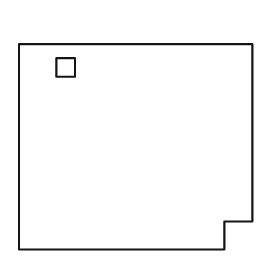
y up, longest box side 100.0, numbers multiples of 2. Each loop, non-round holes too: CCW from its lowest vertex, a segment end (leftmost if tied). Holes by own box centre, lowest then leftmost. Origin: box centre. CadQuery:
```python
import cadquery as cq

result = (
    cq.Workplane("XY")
    .moveTo(-50.0, -44.0)
    .lineTo(38.0, -44.0)
    .lineTo(38.0, -32.0)
    .lineTo(50.0, -32.0)
    .lineTo(50.0, 44.0)
    .lineTo(-50.0, 44.0)
    .close()
    .moveTo(-34.0, 30.0)
    .lineTo(-26.0, 30.0)
    .lineTo(-26.0, 38.0)
    .lineTo(-34.0, 38.0)
    .close()
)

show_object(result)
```